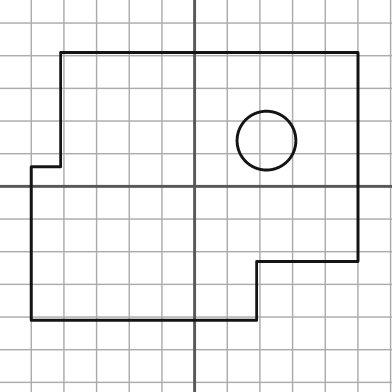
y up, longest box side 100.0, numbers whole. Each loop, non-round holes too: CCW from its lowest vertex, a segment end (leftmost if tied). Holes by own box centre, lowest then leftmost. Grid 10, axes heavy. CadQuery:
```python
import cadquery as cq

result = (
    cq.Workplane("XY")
    .moveTo(-50.0, -41.0)
    .lineTo(19.0, -41.0)
    .lineTo(19.0, -23.0)
    .lineTo(50.0, -23.0)
    .lineTo(50.0, 41.0)
    .lineTo(-41.0, 41.0)
    .lineTo(-41.0, 6.0)
    .lineTo(-50.0, 6.0)
    .close()
    .moveTo(22.0, 14.0)
    .circle(9.0)
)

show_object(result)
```